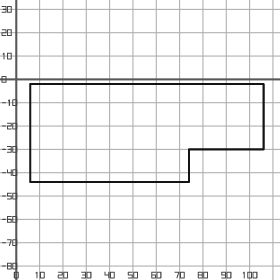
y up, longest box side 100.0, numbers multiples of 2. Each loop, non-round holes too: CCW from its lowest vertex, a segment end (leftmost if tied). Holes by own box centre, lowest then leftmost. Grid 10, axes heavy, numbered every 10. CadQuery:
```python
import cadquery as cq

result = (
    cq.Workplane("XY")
    .moveTo(6.0, -44.0)
    .lineTo(74.0, -44.0)
    .lineTo(74.0, -30.0)
    .lineTo(106.0, -30.0)
    .lineTo(106.0, -2.0)
    .lineTo(6.0, -2.0)
    .close()
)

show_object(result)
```